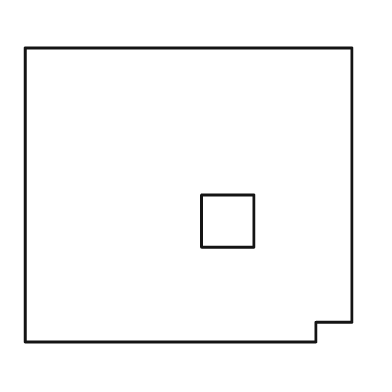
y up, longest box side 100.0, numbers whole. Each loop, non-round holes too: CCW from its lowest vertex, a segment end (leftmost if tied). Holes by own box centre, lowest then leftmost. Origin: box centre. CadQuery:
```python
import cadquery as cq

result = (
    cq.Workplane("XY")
    .moveTo(-50.0, -45.0)
    .lineTo(39.0, -45.0)
    .lineTo(39.0, -39.0)
    .lineTo(50.0, -39.0)
    .lineTo(50.0, 45.0)
    .lineTo(-50.0, 45.0)
    .close()
    .moveTo(4.0, -16.0)
    .lineTo(20.0, -16.0)
    .lineTo(20.0, 0.0)
    .lineTo(4.0, 0.0)
    .close()
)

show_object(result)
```